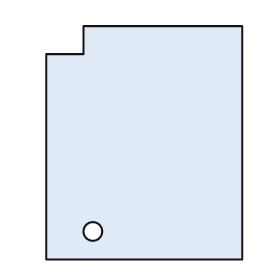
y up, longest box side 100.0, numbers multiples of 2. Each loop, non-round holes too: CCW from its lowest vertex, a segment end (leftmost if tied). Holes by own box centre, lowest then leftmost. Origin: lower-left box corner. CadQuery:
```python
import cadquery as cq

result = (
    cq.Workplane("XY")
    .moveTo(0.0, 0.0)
    .lineTo(84.0, 0.0)
    .lineTo(84.0, 100.0)
    .lineTo(16.0, 100.0)
    .lineTo(16.0, 88.0)
    .lineTo(0.0, 88.0)
    .close()
    .moveTo(20.0, 12.0)
    .circle(4.0)
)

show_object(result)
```